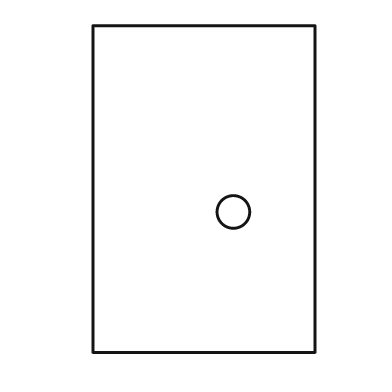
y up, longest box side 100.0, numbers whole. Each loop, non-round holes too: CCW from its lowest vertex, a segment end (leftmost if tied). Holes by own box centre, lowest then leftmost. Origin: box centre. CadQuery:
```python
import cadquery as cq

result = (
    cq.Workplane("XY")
    .moveTo(-34.0, -50.0)
    .lineTo(34.0, -50.0)
    .lineTo(34.0, 50.0)
    .lineTo(-34.0, 50.0)
    .close()
    .moveTo(9.0, -7.0)
    .circle(5.0)
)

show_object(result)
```